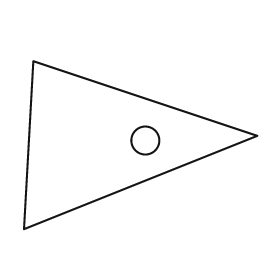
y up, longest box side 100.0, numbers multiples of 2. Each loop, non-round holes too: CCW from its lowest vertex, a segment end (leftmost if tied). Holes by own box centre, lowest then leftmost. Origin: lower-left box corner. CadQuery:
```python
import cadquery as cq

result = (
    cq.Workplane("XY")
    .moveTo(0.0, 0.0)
    .lineTo(100.0, 40.0)
    .lineTo(4.0, 72.0)
    .close()
    .moveTo(52.0, 38.0)
    .circle(6.0)
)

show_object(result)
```